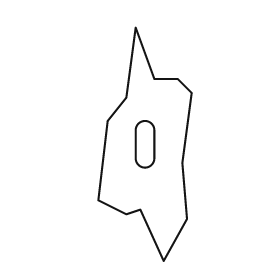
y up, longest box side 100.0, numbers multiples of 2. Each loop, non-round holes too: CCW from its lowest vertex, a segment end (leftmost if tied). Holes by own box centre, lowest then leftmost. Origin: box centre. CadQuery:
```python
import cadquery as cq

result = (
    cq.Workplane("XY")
    .moveTo(8.0, -50.0)
    .lineTo(18.0, -32.0)
    .lineTo(16.0, -8.0)
    .lineTo(20.0, 22.0)
    .lineTo(14.0, 28.0)
    .lineTo(4.0, 28.0)
    .lineTo(-4.0, 50.0)
    .lineTo(-8.0, 20.0)
    .lineTo(-16.0, 10.0)
    .lineTo(-20.0, -24.0)
    .lineTo(-8.0, -30.0)
    .lineTo(-2.0, -28.0)
    .close()
    .moveTo(-4.0, -6.0)
    .threePointArc((0.0, -10.0), (4.0, -6.0))
    .lineTo(4.0, 6.0)
    .threePointArc((0.0, 10.0), (-4.0, 6.0))
    .close()
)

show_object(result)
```